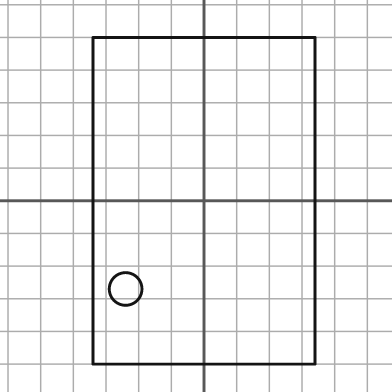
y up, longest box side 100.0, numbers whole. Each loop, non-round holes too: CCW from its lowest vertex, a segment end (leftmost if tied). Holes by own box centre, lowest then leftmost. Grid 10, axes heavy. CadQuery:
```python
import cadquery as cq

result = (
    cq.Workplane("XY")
    .moveTo(-34.0, -50.0)
    .lineTo(34.0, -50.0)
    .lineTo(34.0, 50.0)
    .lineTo(-34.0, 50.0)
    .close()
    .moveTo(-24.0, -27.0)
    .circle(5.0)
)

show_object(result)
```